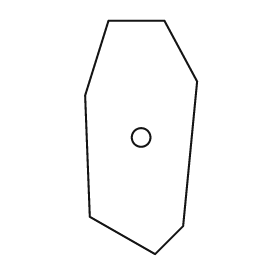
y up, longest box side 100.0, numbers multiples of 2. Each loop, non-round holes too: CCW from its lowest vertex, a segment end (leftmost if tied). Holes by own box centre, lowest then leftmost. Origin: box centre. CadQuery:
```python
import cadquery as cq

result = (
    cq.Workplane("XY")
    .moveTo(6.0, -50.0)
    .lineTo(18.0, -38.0)
    .lineTo(24.0, 24.0)
    .lineTo(10.0, 50.0)
    .lineTo(-14.0, 50.0)
    .lineTo(-24.0, 18.0)
    .lineTo(-22.0, -34.0)
    .close()
    .moveTo(0.0, 0.0)
    .circle(4.0)
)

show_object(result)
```